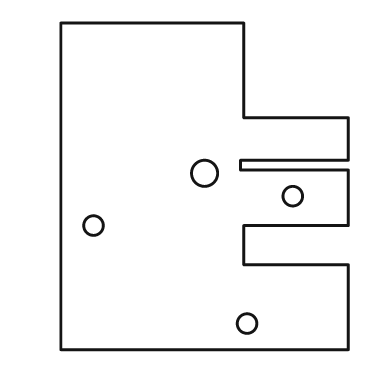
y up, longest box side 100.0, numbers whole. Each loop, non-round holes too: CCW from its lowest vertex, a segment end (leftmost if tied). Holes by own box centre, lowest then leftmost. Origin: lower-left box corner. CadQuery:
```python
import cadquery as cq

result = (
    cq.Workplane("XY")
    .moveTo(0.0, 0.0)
    .lineTo(88.0, 0.0)
    .lineTo(88.0, 26.0)
    .lineTo(56.0, 26.0)
    .lineTo(56.0, 38.0)
    .lineTo(88.0, 38.0)
    .lineTo(88.0, 55.0)
    .lineTo(55.0, 55.0)
    .lineTo(55.0, 58.0)
    .lineTo(88.0, 58.0)
    .lineTo(88.0, 71.0)
    .lineTo(56.0, 71.0)
    .lineTo(56.0, 100.0)
    .lineTo(0.0, 100.0)
    .close()
    .moveTo(57.0, 8.0)
    .circle(3.0)
    .moveTo(10.0, 38.0)
    .circle(3.0)
    .moveTo(71.0, 47.0)
    .circle(3.0)
    .moveTo(44.0, 54.0)
    .circle(4.0)
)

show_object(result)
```